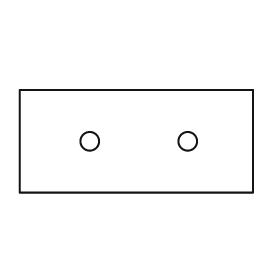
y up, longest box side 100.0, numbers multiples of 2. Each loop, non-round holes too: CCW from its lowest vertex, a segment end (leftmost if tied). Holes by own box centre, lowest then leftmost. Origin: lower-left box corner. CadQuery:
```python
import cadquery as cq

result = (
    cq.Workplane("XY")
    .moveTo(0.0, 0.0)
    .lineTo(100.0, 0.0)
    .lineTo(100.0, 44.0)
    .lineTo(0.0, 44.0)
    .close()
    .moveTo(30.0, 22.0)
    .circle(4.0)
    .moveTo(72.0, 22.0)
    .circle(4.0)
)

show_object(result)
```